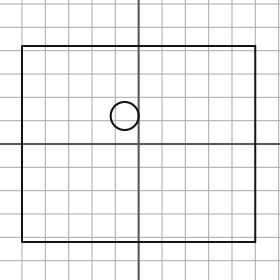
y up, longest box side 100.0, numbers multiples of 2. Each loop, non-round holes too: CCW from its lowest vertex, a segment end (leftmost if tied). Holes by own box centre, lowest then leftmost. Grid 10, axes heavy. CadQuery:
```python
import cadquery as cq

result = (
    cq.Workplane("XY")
    .moveTo(-50.0, -42.0)
    .lineTo(50.0, -42.0)
    .lineTo(50.0, 42.0)
    .lineTo(-50.0, 42.0)
    .close()
    .moveTo(-6.0, 12.0)
    .circle(6.0)
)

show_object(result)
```